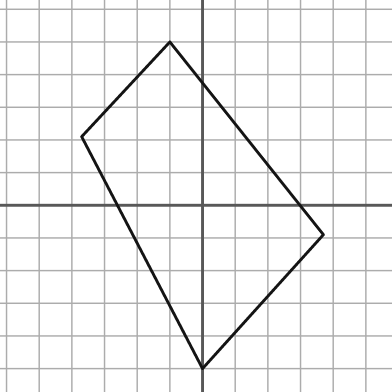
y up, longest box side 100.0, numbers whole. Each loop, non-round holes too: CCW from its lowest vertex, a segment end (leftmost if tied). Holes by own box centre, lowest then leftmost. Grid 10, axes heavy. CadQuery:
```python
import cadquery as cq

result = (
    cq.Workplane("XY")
    .moveTo(0.0, -50.0)
    .lineTo(37.0, -9.0)
    .lineTo(-10.0, 50.0)
    .lineTo(-37.0, 21.0)
    .close()
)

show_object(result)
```